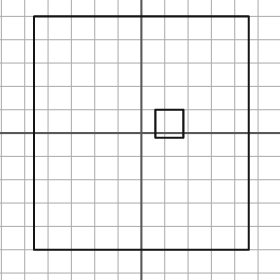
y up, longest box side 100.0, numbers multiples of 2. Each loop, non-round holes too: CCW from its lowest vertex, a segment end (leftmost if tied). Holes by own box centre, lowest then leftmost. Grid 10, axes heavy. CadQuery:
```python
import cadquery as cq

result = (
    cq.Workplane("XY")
    .moveTo(-46.0, -50.0)
    .lineTo(46.0, -50.0)
    .lineTo(46.0, 50.0)
    .lineTo(-46.0, 50.0)
    .close()
    .moveTo(6.0, -2.0)
    .lineTo(18.0, -2.0)
    .lineTo(18.0, 10.0)
    .lineTo(6.0, 10.0)
    .close()
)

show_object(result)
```